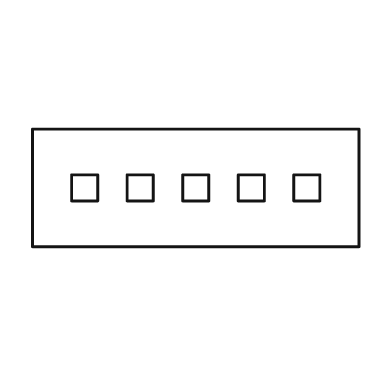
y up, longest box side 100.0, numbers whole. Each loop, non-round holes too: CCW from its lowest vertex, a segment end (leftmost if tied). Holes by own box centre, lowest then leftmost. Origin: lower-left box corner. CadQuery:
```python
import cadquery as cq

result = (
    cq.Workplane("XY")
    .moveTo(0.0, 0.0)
    .lineTo(100.0, 0.0)
    .lineTo(100.0, 36.0)
    .lineTo(0.0, 36.0)
    .close()
    .moveTo(12.0, 14.0)
    .lineTo(20.0, 14.0)
    .lineTo(20.0, 22.0)
    .lineTo(12.0, 22.0)
    .close()
    .moveTo(29.0, 14.0)
    .lineTo(37.0, 14.0)
    .lineTo(37.0, 22.0)
    .lineTo(29.0, 22.0)
    .close()
    .moveTo(46.0, 14.0)
    .lineTo(54.0, 14.0)
    .lineTo(54.0, 22.0)
    .lineTo(46.0, 22.0)
    .close()
    .moveTo(63.0, 14.0)
    .lineTo(71.0, 14.0)
    .lineTo(71.0, 22.0)
    .lineTo(63.0, 22.0)
    .close()
    .moveTo(80.0, 14.0)
    .lineTo(88.0, 14.0)
    .lineTo(88.0, 22.0)
    .lineTo(80.0, 22.0)
    .close()
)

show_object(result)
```